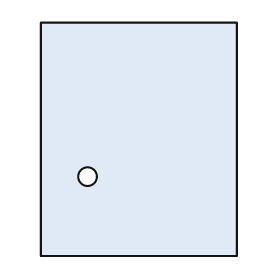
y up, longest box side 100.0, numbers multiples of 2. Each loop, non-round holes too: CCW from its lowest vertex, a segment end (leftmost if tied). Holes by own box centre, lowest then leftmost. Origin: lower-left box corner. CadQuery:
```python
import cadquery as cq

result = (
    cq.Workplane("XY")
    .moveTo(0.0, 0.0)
    .lineTo(84.0, 0.0)
    .lineTo(84.0, 100.0)
    .lineTo(0.0, 100.0)
    .close()
    .moveTo(20.0, 34.0)
    .circle(4.0)
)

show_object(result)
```